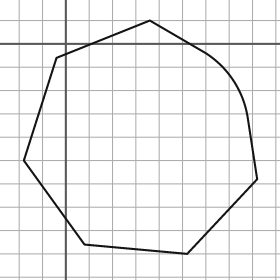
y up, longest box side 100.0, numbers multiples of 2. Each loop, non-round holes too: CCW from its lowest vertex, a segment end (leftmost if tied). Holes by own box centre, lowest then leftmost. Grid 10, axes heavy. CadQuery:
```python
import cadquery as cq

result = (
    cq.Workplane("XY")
    .moveTo(52.0, -90.0)
    .lineTo(82.0, -58.0)
    .lineTo(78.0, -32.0)
    .threePointArc((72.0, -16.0), (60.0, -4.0))
    .lineTo(36.0, 10.0)
    .lineTo(-4.0, -6.0)
    .lineTo(-18.0, -50.0)
    .lineTo(8.0, -86.0)
    .close()
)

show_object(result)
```